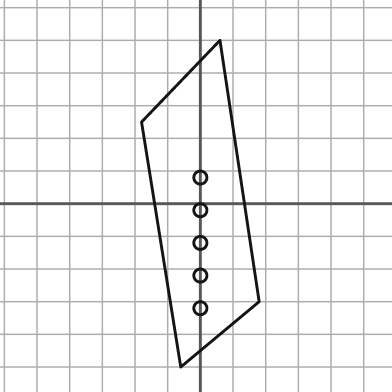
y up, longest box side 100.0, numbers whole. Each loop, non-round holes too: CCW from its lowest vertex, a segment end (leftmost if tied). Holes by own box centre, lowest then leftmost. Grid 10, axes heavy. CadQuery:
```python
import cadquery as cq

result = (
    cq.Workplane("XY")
    .moveTo(-6.0, -50.0)
    .lineTo(18.0, -30.0)
    .lineTo(6.0, 50.0)
    .lineTo(-18.0, 25.0)
    .close()
    .moveTo(0.0, -32.0)
    .circle(2.0)
    .moveTo(0.0, -22.0)
    .circle(2.0)
    .moveTo(0.0, -12.0)
    .circle(2.0)
    .moveTo(0.0, -2.0)
    .circle(2.0)
    .moveTo(0.0, 8.0)
    .circle(2.0)
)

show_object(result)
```